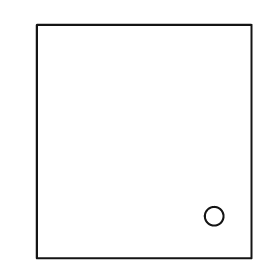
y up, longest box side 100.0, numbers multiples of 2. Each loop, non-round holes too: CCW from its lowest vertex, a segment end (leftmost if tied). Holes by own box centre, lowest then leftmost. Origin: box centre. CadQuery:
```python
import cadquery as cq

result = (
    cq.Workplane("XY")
    .moveTo(-46.0, -50.0)
    .lineTo(46.0, -50.0)
    .lineTo(46.0, 50.0)
    .lineTo(-46.0, 50.0)
    .close()
    .moveTo(30.0, -32.0)
    .circle(4.0)
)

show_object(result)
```